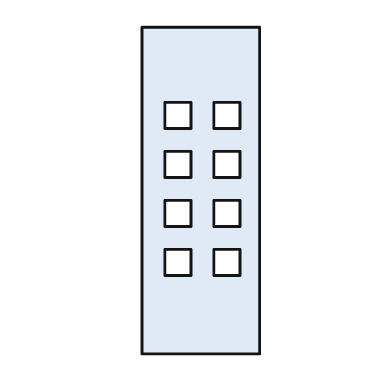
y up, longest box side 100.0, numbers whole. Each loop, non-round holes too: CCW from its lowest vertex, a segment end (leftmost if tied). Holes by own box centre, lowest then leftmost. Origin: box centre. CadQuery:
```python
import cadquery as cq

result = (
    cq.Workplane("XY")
    .moveTo(-18.0, -50.0)
    .lineTo(18.0, -50.0)
    .lineTo(18.0, 50.0)
    .lineTo(-18.0, 50.0)
    .close()
    .moveTo(-11.0, -26.0)
    .lineTo(-3.0, -26.0)
    .lineTo(-3.0, -18.0)
    .lineTo(-11.0, -18.0)
    .close()
    .moveTo(4.0, -26.0)
    .lineTo(12.0, -26.0)
    .lineTo(12.0, -18.0)
    .lineTo(4.0, -18.0)
    .close()
    .moveTo(-11.0, -11.0)
    .lineTo(-3.0, -11.0)
    .lineTo(-3.0, -3.0)
    .lineTo(-11.0, -3.0)
    .close()
    .moveTo(4.0, -11.0)
    .lineTo(12.0, -11.0)
    .lineTo(12.0, -3.0)
    .lineTo(4.0, -3.0)
    .close()
    .moveTo(-11.0, 4.0)
    .lineTo(-3.0, 4.0)
    .lineTo(-3.0, 12.0)
    .lineTo(-11.0, 12.0)
    .close()
    .moveTo(4.0, 4.0)
    .lineTo(12.0, 4.0)
    .lineTo(12.0, 12.0)
    .lineTo(4.0, 12.0)
    .close()
    .moveTo(-11.0, 19.0)
    .lineTo(-3.0, 19.0)
    .lineTo(-3.0, 27.0)
    .lineTo(-11.0, 27.0)
    .close()
    .moveTo(4.0, 19.0)
    .lineTo(12.0, 19.0)
    .lineTo(12.0, 27.0)
    .lineTo(4.0, 27.0)
    .close()
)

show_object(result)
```